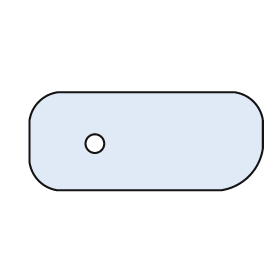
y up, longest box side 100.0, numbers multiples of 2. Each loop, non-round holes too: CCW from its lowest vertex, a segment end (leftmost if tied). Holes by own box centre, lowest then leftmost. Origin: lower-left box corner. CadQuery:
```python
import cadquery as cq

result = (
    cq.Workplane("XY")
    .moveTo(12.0, 0.0)
    .lineTo(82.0, 0.0)
    .threePointArc((94.0, 6.0), (100.0, 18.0))
    .lineTo(100.0, 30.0)
    .threePointArc((96.0, 38.0), (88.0, 42.0))
    .lineTo(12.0, 42.0)
    .threePointArc((4.0, 38.0), (0.0, 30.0))
    .lineTo(0.0, 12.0)
    .threePointArc((4.0, 4.0), (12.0, 0.0))
    .close()
    .moveTo(28.0, 20.0)
    .circle(4.0)
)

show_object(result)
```